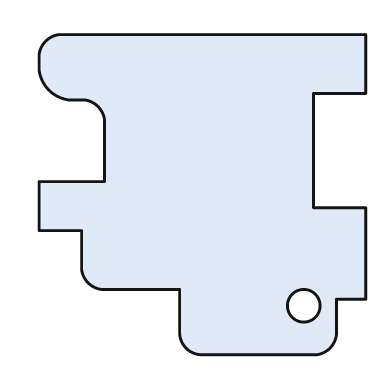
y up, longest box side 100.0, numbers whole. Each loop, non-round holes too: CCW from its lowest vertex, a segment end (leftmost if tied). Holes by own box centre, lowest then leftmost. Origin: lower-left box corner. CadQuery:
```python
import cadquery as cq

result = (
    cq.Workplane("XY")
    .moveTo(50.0, 0.0)
    .lineTo(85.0, 0.0)
    .threePointArc((89.0, 2.0), (91.0, 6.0))
    .lineTo(91.0, 17.0)
    .lineTo(100.0, 17.0)
    .lineTo(100.0, 45.0)
    .lineTo(84.0, 45.0)
    .lineTo(84.0, 80.0)
    .lineTo(100.0, 80.0)
    .lineTo(100.0, 98.0)
    .lineTo(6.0, 98.0)
    .threePointArc((2.0, 96.0), (0.0, 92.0))
    .lineTo(0.0, 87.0)
    .threePointArc((3.0, 81.0), (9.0, 78.0))
    .lineTo(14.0, 78.0)
    .threePointArc((18.0, 76.0), (20.0, 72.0))
    .lineTo(20.0, 53.0)
    .lineTo(0.0, 53.0)
    .lineTo(0.0, 38.0)
    .lineTo(13.0, 38.0)
    .lineTo(13.0, 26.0)
    .threePointArc((15.0, 22.0), (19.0, 20.0))
    .lineTo(43.0, 20.0)
    .lineTo(43.0, 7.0)
    .threePointArc((45.0, 2.0), (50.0, 0.0))
    .close()
    .moveTo(81.0, 15.0)
    .circle(5.0)
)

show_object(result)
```